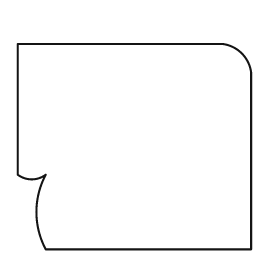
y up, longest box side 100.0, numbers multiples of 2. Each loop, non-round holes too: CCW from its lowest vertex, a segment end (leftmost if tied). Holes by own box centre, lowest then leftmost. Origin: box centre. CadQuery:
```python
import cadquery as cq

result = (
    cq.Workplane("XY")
    .moveTo(-38.0, -44.0)
    .lineTo(50.0, -44.0)
    .lineTo(50.0, 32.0)
    .threePointArc((46.0, 40.0), (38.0, 44.0))
    .lineTo(-50.0, 44.0)
    .lineTo(-50.0, -12.0)
    .threePointArc((-44.0, -14.0), (-38.0, -12.0))
    .threePointArc((-42.0, -28.0), (-38.0, -44.0))
    .close()
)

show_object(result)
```